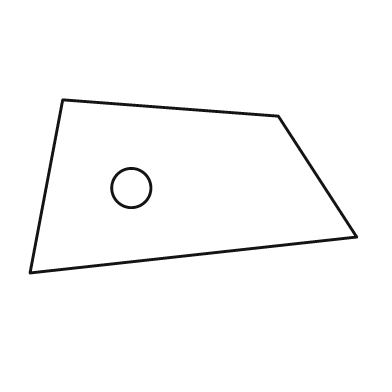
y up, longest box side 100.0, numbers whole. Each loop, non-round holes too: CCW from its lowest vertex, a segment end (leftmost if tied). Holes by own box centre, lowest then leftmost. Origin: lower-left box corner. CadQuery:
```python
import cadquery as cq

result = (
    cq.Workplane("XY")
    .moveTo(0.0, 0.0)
    .lineTo(100.0, 11.0)
    .lineTo(76.0, 48.0)
    .lineTo(10.0, 53.0)
    .close()
    .moveTo(31.0, 26.0)
    .circle(6.0)
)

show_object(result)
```